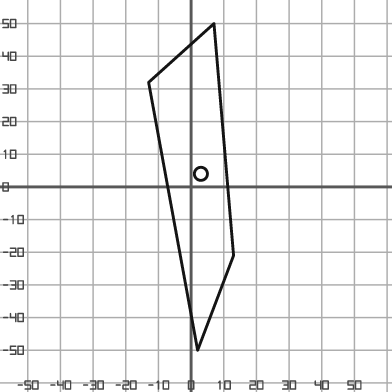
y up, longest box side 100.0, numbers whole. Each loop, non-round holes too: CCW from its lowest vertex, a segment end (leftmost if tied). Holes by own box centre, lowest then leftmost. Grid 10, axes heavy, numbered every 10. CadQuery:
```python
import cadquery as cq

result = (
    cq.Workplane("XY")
    .moveTo(2.0, -50.0)
    .lineTo(13.0, -21.0)
    .lineTo(7.0, 50.0)
    .lineTo(-13.0, 32.0)
    .close()
    .moveTo(3.0, 4.0)
    .circle(2.0)
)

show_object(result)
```